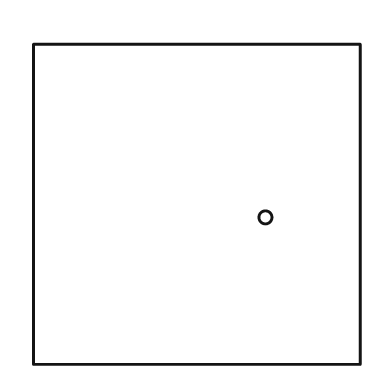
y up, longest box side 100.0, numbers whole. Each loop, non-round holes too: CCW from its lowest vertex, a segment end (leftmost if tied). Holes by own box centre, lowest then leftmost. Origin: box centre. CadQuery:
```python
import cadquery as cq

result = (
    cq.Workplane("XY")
    .moveTo(-50.0, -49.0)
    .lineTo(50.0, -49.0)
    .lineTo(50.0, 49.0)
    .lineTo(-50.0, 49.0)
    .close()
    .moveTo(21.0, -4.0)
    .circle(2.0)
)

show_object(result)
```